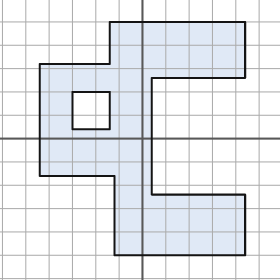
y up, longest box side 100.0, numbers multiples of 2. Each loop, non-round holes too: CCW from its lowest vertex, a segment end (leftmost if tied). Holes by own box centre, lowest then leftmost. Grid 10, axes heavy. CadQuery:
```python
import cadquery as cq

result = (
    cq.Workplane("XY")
    .moveTo(-12.0, -50.0)
    .lineTo(44.0, -50.0)
    .lineTo(44.0, -24.0)
    .lineTo(4.0, -24.0)
    .lineTo(4.0, 26.0)
    .lineTo(44.0, 26.0)
    .lineTo(44.0, 50.0)
    .lineTo(-14.0, 50.0)
    .lineTo(-14.0, 32.0)
    .lineTo(-44.0, 32.0)
    .lineTo(-44.0, -16.0)
    .lineTo(-12.0, -16.0)
    .close()
    .moveTo(-30.0, 4.0)
    .lineTo(-14.0, 4.0)
    .lineTo(-14.0, 20.0)
    .lineTo(-30.0, 20.0)
    .close()
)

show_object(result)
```